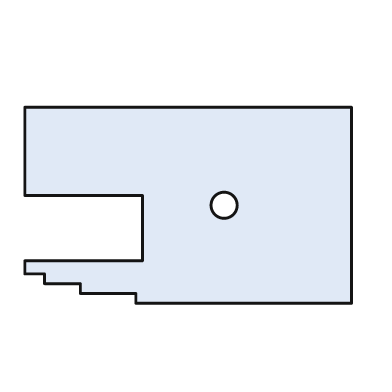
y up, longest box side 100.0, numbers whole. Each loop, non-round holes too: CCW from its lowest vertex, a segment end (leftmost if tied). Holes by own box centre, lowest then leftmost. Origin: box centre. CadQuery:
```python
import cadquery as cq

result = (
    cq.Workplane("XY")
    .moveTo(-16.0, -30.0)
    .lineTo(50.0, -30.0)
    .lineTo(50.0, 30.0)
    .lineTo(-50.0, 30.0)
    .lineTo(-50.0, 3.0)
    .lineTo(-14.0, 3.0)
    .lineTo(-14.0, -17.0)
    .lineTo(-50.0, -17.0)
    .lineTo(-50.0, -21.0)
    .lineTo(-44.0, -21.0)
    .lineTo(-44.0, -24.0)
    .lineTo(-33.0, -24.0)
    .lineTo(-33.0, -27.0)
    .lineTo(-16.0, -27.0)
    .close()
    .moveTo(11.0, 0.0)
    .circle(4.0)
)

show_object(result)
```